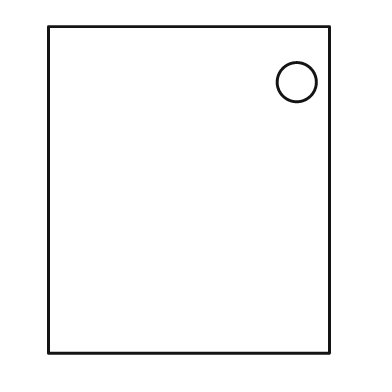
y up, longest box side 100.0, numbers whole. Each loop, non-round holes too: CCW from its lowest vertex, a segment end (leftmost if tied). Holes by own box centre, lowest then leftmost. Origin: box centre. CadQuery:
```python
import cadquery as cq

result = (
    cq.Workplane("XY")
    .moveTo(-43.0, -50.0)
    .lineTo(43.0, -50.0)
    .lineTo(43.0, 50.0)
    .lineTo(-43.0, 50.0)
    .close()
    .moveTo(33.0, 33.0)
    .circle(6.0)
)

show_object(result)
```